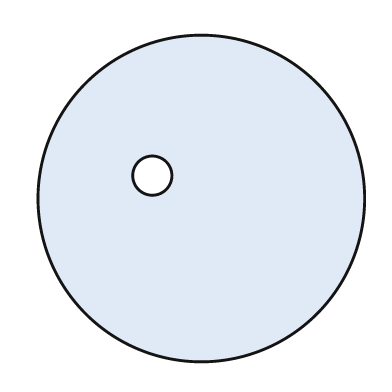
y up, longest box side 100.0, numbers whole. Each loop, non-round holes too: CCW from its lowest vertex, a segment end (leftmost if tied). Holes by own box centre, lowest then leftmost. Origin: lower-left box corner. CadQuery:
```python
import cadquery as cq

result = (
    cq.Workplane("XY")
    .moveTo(50.0, 50.0)
    .circle(50.0)
    .moveTo(35.0, 57.0)
    .circle(6.0)
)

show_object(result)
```